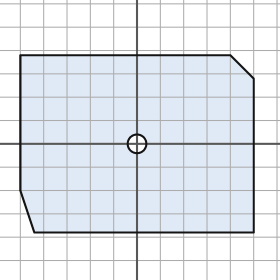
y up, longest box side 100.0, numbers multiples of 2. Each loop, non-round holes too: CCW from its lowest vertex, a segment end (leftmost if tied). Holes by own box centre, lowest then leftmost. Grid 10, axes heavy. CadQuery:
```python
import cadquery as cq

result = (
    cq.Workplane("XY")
    .moveTo(-44.0, -38.0)
    .lineTo(50.0, -38.0)
    .lineTo(50.0, 28.0)
    .lineTo(40.0, 38.0)
    .lineTo(-50.0, 38.0)
    .lineTo(-50.0, -20.0)
    .close()
    .moveTo(0.0, 0.0)
    .circle(4.0)
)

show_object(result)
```